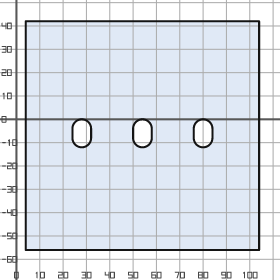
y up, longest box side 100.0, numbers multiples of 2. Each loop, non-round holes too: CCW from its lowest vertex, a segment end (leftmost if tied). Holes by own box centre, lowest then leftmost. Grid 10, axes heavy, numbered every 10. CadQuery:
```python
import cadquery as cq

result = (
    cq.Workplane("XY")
    .moveTo(4.0, -56.0)
    .lineTo(104.0, -56.0)
    .lineTo(104.0, 42.0)
    .lineTo(4.0, 42.0)
    .close()
    .moveTo(24.0, -8.0)
    .threePointArc((28.0, -12.0), (32.0, -8.0))
    .lineTo(32.0, -4.0)
    .threePointArc((28.0, 0.0), (24.0, -4.0))
    .close()
    .moveTo(50.0, -8.0)
    .threePointArc((54.0, -12.0), (58.0, -8.0))
    .lineTo(58.0, -4.0)
    .threePointArc((54.0, 0.0), (50.0, -4.0))
    .close()
    .moveTo(76.0, -8.0)
    .threePointArc((80.0, -12.0), (84.0, -8.0))
    .lineTo(84.0, -4.0)
    .threePointArc((80.0, 0.0), (76.0, -4.0))
    .close()
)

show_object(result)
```